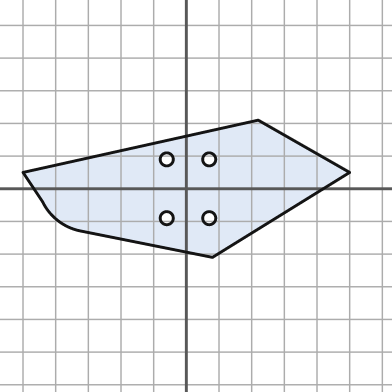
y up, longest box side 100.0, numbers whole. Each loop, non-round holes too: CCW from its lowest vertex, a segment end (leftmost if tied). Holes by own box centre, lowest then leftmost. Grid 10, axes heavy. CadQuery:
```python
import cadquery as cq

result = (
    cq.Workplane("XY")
    .moveTo(8.0, -21.0)
    .lineTo(50.0, 5.0)
    .lineTo(22.0, 21.0)
    .lineTo(-50.0, 5.0)
    .lineTo(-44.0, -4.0)
    .threePointArc((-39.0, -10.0), (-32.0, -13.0))
    .close()
    .moveTo(-6.0, -9.0)
    .circle(2.0)
    .moveTo(7.0, -9.0)
    .circle(2.0)
    .moveTo(-6.0, 9.0)
    .circle(2.0)
    .moveTo(7.0, 9.0)
    .circle(2.0)
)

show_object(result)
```